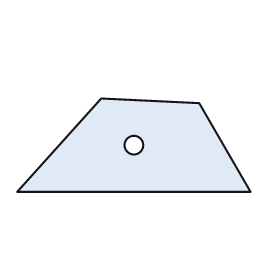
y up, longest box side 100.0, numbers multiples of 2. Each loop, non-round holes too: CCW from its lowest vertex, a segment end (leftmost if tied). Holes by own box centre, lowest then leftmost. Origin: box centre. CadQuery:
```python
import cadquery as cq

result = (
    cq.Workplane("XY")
    .moveTo(-50.0, -20.0)
    .lineTo(50.0, -20.0)
    .lineTo(28.0, 18.0)
    .lineTo(-14.0, 20.0)
    .close()
    .moveTo(0.0, 0.0)
    .circle(4.0)
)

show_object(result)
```